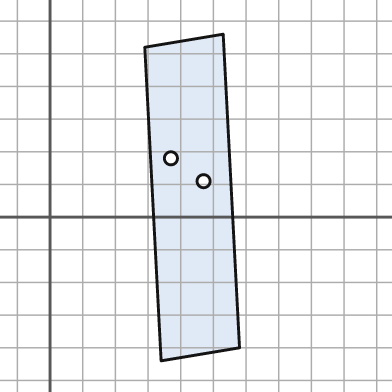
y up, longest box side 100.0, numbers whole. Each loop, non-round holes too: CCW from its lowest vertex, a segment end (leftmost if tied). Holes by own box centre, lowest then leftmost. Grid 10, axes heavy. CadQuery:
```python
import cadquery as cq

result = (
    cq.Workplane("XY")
    .moveTo(34.0, -44.0)
    .lineTo(58.0, -40.0)
    .lineTo(53.0, 56.0)
    .lineTo(29.0, 52.0)
    .close()
    .moveTo(47.0, 11.0)
    .circle(2.0)
    .moveTo(37.0, 18.0)
    .circle(2.0)
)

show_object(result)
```